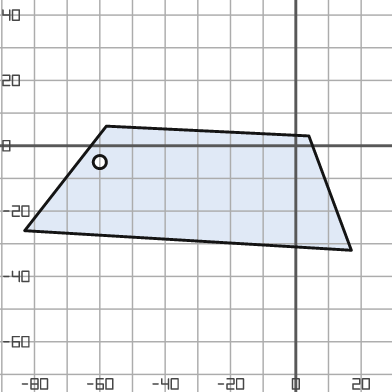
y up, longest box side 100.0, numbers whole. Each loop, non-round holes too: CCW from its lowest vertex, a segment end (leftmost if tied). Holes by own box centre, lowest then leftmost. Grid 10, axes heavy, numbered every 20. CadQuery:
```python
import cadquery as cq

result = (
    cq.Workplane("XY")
    .moveTo(17.0, -32.0)
    .lineTo(4.0, 3.0)
    .lineTo(-58.0, 6.0)
    .lineTo(-83.0, -26.0)
    .close()
    .moveTo(-60.0, -5.0)
    .circle(2.0)
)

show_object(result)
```